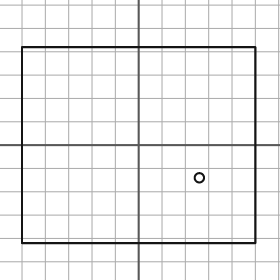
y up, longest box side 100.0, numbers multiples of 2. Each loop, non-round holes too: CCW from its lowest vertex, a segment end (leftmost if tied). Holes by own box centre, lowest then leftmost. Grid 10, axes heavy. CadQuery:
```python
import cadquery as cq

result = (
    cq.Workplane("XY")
    .moveTo(-50.0, -42.0)
    .lineTo(50.0, -42.0)
    .lineTo(50.0, 42.0)
    .lineTo(-50.0, 42.0)
    .close()
    .moveTo(26.0, -14.0)
    .circle(2.0)
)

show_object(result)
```